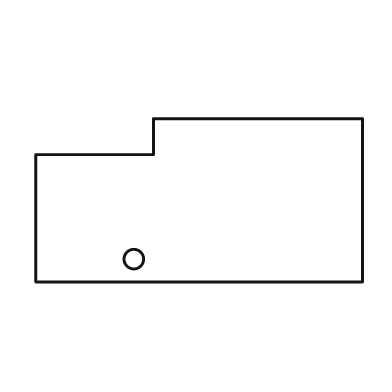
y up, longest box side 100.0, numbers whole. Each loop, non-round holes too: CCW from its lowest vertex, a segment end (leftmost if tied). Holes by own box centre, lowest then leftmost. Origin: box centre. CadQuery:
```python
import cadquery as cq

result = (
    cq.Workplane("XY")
    .moveTo(-50.0, -25.0)
    .lineTo(50.0, -25.0)
    .lineTo(50.0, 25.0)
    .lineTo(-14.0, 25.0)
    .lineTo(-14.0, 14.0)
    .lineTo(-50.0, 14.0)
    .close()
    .moveTo(-20.0, -18.0)
    .circle(3.0)
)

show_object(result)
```